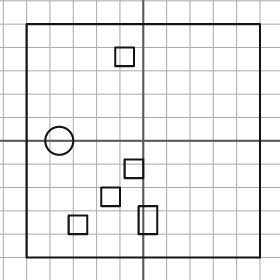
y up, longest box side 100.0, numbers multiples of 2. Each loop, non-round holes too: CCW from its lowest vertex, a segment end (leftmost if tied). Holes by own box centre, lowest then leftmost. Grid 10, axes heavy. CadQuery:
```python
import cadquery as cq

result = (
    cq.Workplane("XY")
    .moveTo(-50.0, -50.0)
    .lineTo(50.0, -50.0)
    .lineTo(50.0, 50.0)
    .lineTo(-50.0, 50.0)
    .close()
    .moveTo(-32.0, -40.0)
    .lineTo(-24.0, -40.0)
    .lineTo(-24.0, -32.0)
    .lineTo(-32.0, -32.0)
    .close()
    .moveTo(-2.0, -40.0)
    .lineTo(6.0, -40.0)
    .lineTo(6.0, -28.0)
    .lineTo(-2.0, -28.0)
    .close()
    .moveTo(-18.0, -28.0)
    .lineTo(-10.0, -28.0)
    .lineTo(-10.0, -20.0)
    .lineTo(-18.0, -20.0)
    .close()
    .moveTo(-8.0, -16.0)
    .lineTo(0.0, -16.0)
    .lineTo(0.0, -8.0)
    .lineTo(-8.0, -8.0)
    .close()
    .moveTo(-36.0, 0.0)
    .circle(6.0)
    .moveTo(-12.0, 32.0)
    .lineTo(-4.0, 32.0)
    .lineTo(-4.0, 40.0)
    .lineTo(-12.0, 40.0)
    .close()
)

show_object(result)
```